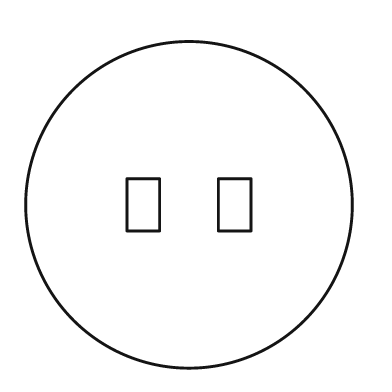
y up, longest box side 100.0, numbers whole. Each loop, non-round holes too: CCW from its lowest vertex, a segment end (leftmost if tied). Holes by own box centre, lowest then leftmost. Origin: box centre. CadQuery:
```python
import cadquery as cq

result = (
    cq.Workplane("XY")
    .moveTo(0.0, 0.0)
    .circle(50.0)
    .moveTo(-19.0, -8.0)
    .lineTo(-9.0, -8.0)
    .lineTo(-9.0, 8.0)
    .lineTo(-19.0, 8.0)
    .close()
    .moveTo(9.0, -8.0)
    .lineTo(19.0, -8.0)
    .lineTo(19.0, 8.0)
    .lineTo(9.0, 8.0)
    .close()
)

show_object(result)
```